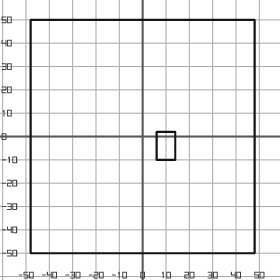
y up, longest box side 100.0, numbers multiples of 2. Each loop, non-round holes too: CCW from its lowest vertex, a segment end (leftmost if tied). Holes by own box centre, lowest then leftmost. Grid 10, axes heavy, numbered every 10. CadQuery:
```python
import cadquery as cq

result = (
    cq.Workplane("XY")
    .moveTo(-48.0, -50.0)
    .lineTo(48.0, -50.0)
    .lineTo(48.0, 50.0)
    .lineTo(-48.0, 50.0)
    .close()
    .moveTo(6.0, -10.0)
    .lineTo(14.0, -10.0)
    .lineTo(14.0, 2.0)
    .lineTo(6.0, 2.0)
    .close()
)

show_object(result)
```